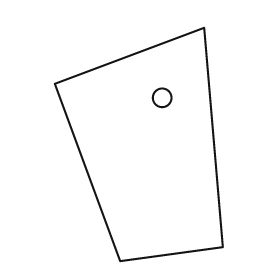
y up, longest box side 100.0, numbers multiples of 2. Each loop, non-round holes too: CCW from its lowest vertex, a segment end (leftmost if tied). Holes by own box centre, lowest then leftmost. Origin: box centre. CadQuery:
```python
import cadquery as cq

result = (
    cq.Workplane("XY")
    .moveTo(-8.0, -50.0)
    .lineTo(36.0, -44.0)
    .lineTo(28.0, 50.0)
    .lineTo(-36.0, 26.0)
    .close()
    .moveTo(10.0, 20.0)
    .circle(4.0)
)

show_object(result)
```